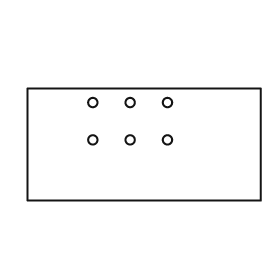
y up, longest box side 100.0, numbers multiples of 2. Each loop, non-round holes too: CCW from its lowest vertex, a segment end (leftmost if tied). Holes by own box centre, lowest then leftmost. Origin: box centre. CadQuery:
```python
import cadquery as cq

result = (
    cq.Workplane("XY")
    .moveTo(-50.0, -24.0)
    .lineTo(50.0, -24.0)
    .lineTo(50.0, 24.0)
    .lineTo(-50.0, 24.0)
    .close()
    .moveTo(-22.0, 2.0)
    .circle(2.0)
    .moveTo(-6.0, 2.0)
    .circle(2.0)
    .moveTo(10.0, 2.0)
    .circle(2.0)
    .moveTo(-22.0, 18.0)
    .circle(2.0)
    .moveTo(-6.0, 18.0)
    .circle(2.0)
    .moveTo(10.0, 18.0)
    .circle(2.0)
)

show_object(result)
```